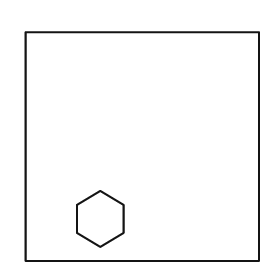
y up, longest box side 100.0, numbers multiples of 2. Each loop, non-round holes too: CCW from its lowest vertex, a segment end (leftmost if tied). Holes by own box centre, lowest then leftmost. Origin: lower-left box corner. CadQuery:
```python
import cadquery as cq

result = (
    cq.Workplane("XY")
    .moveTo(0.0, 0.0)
    .lineTo(100.0, 0.0)
    .lineTo(100.0, 98.0)
    .lineTo(0.0, 98.0)
    .close()
    .moveTo(32.0, 6.0)
    .lineTo(42.0, 12.0)
    .lineTo(42.0, 24.0)
    .lineTo(32.0, 30.0)
    .lineTo(22.0, 24.0)
    .lineTo(22.0, 12.0)
    .close()
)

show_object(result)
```